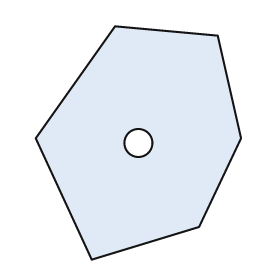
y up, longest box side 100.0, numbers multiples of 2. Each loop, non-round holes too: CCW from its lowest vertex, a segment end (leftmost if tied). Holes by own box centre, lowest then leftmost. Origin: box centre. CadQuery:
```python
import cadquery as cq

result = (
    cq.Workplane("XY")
    .moveTo(-20.0, -50.0)
    .lineTo(26.0, -36.0)
    .lineTo(44.0, 2.0)
    .lineTo(34.0, 46.0)
    .lineTo(-10.0, 50.0)
    .lineTo(-44.0, 2.0)
    .close()
    .moveTo(0.0, 0.0)
    .circle(6.0)
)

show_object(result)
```